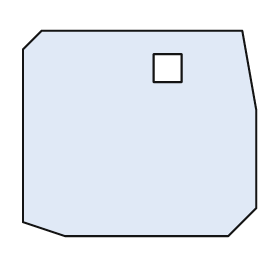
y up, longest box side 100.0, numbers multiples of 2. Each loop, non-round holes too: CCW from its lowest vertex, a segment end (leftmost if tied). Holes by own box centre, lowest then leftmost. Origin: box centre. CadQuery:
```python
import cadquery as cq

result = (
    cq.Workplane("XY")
    .moveTo(-32.0, -44.0)
    .lineTo(38.0, -44.0)
    .lineTo(50.0, -32.0)
    .lineTo(50.0, 10.0)
    .lineTo(44.0, 44.0)
    .lineTo(-42.0, 44.0)
    .lineTo(-50.0, 36.0)
    .lineTo(-50.0, -38.0)
    .close()
    .moveTo(6.0, 22.0)
    .lineTo(18.0, 22.0)
    .lineTo(18.0, 34.0)
    .lineTo(6.0, 34.0)
    .close()
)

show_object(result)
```